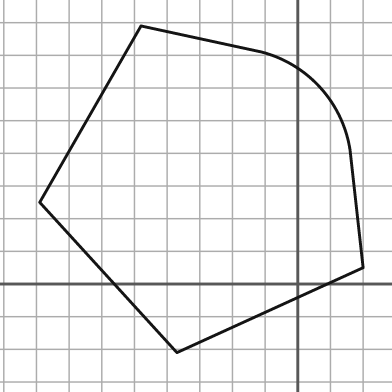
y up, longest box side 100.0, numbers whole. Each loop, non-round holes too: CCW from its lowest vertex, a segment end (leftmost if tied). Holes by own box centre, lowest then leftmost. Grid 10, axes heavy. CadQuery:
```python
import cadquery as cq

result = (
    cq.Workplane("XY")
    .moveTo(-37.0, -21.0)
    .lineTo(20.0, 5.0)
    .lineTo(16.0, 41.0)
    .threePointArc((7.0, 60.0), (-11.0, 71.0))
    .lineTo(-48.0, 79.0)
    .lineTo(-79.0, 25.0)
    .close()
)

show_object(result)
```